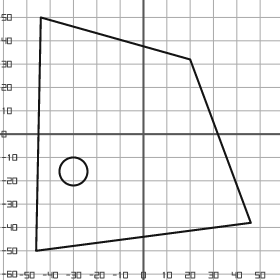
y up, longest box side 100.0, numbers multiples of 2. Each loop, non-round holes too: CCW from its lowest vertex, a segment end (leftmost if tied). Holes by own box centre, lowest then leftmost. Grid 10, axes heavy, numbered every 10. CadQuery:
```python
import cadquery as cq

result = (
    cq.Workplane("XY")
    .moveTo(-46.0, -50.0)
    .lineTo(46.0, -38.0)
    .lineTo(20.0, 32.0)
    .lineTo(-44.0, 50.0)
    .close()
    .moveTo(-30.0, -16.0)
    .circle(6.0)
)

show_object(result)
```